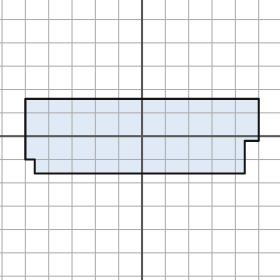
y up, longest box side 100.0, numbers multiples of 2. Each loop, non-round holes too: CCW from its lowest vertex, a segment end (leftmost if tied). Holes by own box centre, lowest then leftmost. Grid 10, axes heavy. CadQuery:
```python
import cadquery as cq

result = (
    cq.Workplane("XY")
    .moveTo(-46.0, -16.0)
    .lineTo(44.0, -16.0)
    .lineTo(44.0, -2.0)
    .lineTo(50.0, -2.0)
    .lineTo(50.0, 16.0)
    .lineTo(-50.0, 16.0)
    .lineTo(-50.0, -10.0)
    .lineTo(-46.0, -10.0)
    .close()
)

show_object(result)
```